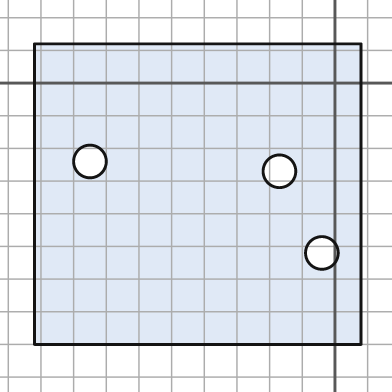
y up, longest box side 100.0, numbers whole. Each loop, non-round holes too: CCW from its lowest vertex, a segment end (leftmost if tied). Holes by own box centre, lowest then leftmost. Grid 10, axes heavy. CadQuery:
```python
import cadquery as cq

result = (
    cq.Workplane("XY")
    .moveTo(-92.0, -80.0)
    .lineTo(8.0, -80.0)
    .lineTo(8.0, 12.0)
    .lineTo(-92.0, 12.0)
    .close()
    .moveTo(-4.0, -52.0)
    .circle(5.0)
    .moveTo(-17.0, -27.0)
    .circle(5.0)
    .moveTo(-75.0, -24.0)
    .circle(5.0)
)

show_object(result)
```